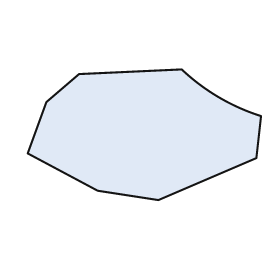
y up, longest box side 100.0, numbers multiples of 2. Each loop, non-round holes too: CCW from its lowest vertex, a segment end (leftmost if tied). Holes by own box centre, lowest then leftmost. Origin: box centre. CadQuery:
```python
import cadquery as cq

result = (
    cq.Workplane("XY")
    .moveTo(6.0, -28.0)
    .lineTo(48.0, -10.0)
    .lineTo(50.0, 8.0)
    .threePointArc((32.0, 16.0), (16.0, 28.0))
    .lineTo(-28.0, 26.0)
    .lineTo(-42.0, 14.0)
    .lineTo(-50.0, -8.0)
    .lineTo(-20.0, -24.0)
    .close()
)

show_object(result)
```